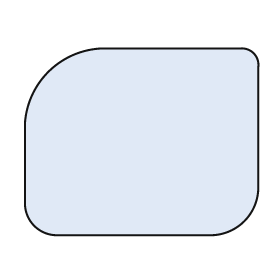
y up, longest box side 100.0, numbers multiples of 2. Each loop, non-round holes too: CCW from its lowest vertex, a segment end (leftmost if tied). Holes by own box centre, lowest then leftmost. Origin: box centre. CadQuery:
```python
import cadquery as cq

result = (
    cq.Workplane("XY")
    .moveTo(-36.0, -40.0)
    .lineTo(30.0, -40.0)
    .threePointArc((44.0, -34.0), (50.0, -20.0))
    .lineTo(50.0, 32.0)
    .threePointArc((48.0, 38.0), (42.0, 40.0))
    .lineTo(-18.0, 40.0)
    .threePointArc((-40.0, 30.0), (-50.0, 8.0))
    .lineTo(-50.0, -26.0)
    .threePointArc((-46.0, -36.0), (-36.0, -40.0))
    .close()
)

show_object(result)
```